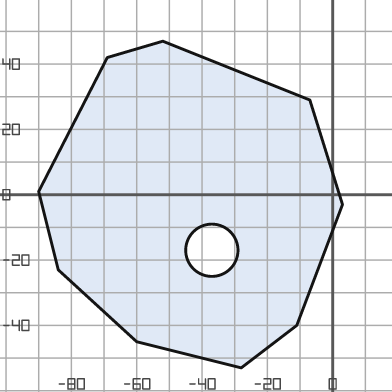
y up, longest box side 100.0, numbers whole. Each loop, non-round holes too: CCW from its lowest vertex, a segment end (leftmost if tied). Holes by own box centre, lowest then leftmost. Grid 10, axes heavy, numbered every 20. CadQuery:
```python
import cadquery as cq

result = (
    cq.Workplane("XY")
    .moveTo(-28.0, -53.0)
    .lineTo(-11.0, -40.0)
    .lineTo(3.0, -3.0)
    .lineTo(-7.0, 29.0)
    .lineTo(-52.0, 47.0)
    .lineTo(-69.0, 42.0)
    .lineTo(-90.0, 1.0)
    .lineTo(-84.0, -23.0)
    .lineTo(-60.0, -45.0)
    .close()
    .moveTo(-37.0, -17.0)
    .circle(8.0)
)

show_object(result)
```